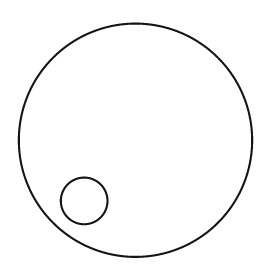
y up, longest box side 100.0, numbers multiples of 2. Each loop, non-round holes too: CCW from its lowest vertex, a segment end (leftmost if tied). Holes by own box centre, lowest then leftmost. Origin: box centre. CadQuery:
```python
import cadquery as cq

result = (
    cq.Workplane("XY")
    .moveTo(0.0, 0.0)
    .circle(50.0)
    .moveTo(-22.0, -26.0)
    .circle(10.0)
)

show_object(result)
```